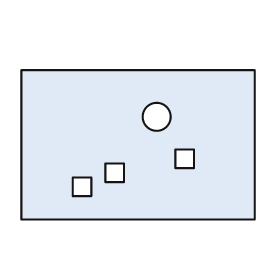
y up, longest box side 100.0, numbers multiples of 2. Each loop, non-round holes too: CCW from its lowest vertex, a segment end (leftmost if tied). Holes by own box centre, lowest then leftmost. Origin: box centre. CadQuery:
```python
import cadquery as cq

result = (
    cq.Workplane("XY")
    .moveTo(-50.0, -32.0)
    .lineTo(50.0, -32.0)
    .lineTo(50.0, 32.0)
    .lineTo(-50.0, 32.0)
    .close()
    .moveTo(-28.0, -22.0)
    .lineTo(-20.0, -22.0)
    .lineTo(-20.0, -14.0)
    .lineTo(-28.0, -14.0)
    .close()
    .moveTo(-14.0, -16.0)
    .lineTo(-6.0, -16.0)
    .lineTo(-6.0, -8.0)
    .lineTo(-14.0, -8.0)
    .close()
    .moveTo(16.0, -10.0)
    .lineTo(24.0, -10.0)
    .lineTo(24.0, -2.0)
    .lineTo(16.0, -2.0)
    .close()
    .moveTo(8.0, 12.0)
    .circle(6.0)
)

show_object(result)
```